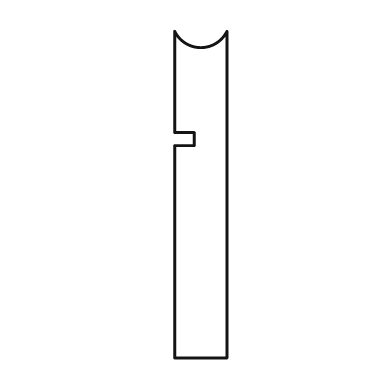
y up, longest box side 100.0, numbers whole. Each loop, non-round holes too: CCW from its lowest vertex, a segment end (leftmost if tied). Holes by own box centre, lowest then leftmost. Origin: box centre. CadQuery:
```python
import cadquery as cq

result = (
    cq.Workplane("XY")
    .moveTo(-8.0, -50.0)
    .lineTo(8.0, -50.0)
    .lineTo(8.0, 50.0)
    .threePointArc((0.0, 45.0), (-8.0, 50.0))
    .lineTo(-8.0, 19.0)
    .lineTo(-2.0, 19.0)
    .lineTo(-2.0, 15.0)
    .lineTo(-8.0, 15.0)
    .close()
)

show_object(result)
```